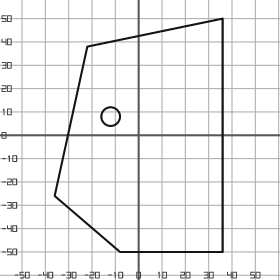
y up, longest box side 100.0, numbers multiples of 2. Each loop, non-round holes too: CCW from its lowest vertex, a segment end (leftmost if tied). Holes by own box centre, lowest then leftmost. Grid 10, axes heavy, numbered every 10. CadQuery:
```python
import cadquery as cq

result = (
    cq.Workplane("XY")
    .moveTo(-8.0, -50.0)
    .lineTo(36.0, -50.0)
    .lineTo(36.0, 50.0)
    .lineTo(-22.0, 38.0)
    .lineTo(-36.0, -26.0)
    .close()
    .moveTo(-12.0, 8.0)
    .circle(4.0)
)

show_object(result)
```